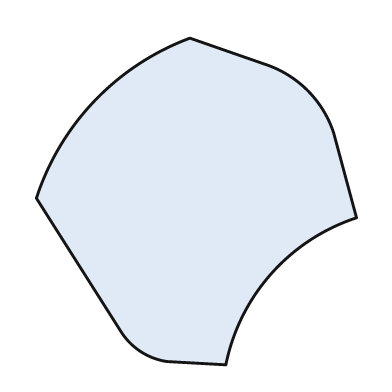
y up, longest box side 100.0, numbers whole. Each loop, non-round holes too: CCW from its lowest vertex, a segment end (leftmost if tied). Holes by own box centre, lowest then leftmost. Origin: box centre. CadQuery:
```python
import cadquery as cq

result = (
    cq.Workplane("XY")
    .moveTo(9.0, -50.0)
    .threePointArc((23.0, -22.0), (49.0, -5.0))
    .lineTo(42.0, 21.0)
    .threePointArc((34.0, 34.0), (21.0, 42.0))
    .lineTo(-2.0, 50.0)
    .threePointArc((-31.0, 31.0), (-49.0, 1.0))
    .lineTo(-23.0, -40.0)
    .threePointArc((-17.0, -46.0), (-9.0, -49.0))
    .close()
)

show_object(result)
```